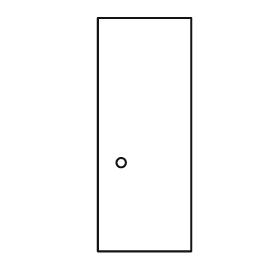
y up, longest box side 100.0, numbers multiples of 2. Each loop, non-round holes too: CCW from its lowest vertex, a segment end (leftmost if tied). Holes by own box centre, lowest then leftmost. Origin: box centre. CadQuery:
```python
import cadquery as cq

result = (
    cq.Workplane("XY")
    .moveTo(-20.0, -50.0)
    .lineTo(20.0, -50.0)
    .lineTo(20.0, 50.0)
    .lineTo(-20.0, 50.0)
    .close()
    .moveTo(-10.0, -12.0)
    .circle(2.0)
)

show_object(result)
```